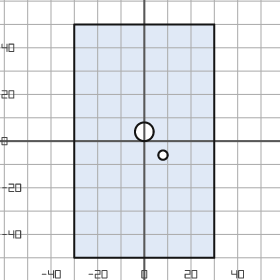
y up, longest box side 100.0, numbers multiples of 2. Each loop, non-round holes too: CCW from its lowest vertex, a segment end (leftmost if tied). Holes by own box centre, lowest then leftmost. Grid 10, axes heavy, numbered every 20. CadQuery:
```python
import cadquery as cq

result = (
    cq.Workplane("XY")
    .moveTo(-30.0, -50.0)
    .lineTo(30.0, -50.0)
    .lineTo(30.0, 50.0)
    .lineTo(-30.0, 50.0)
    .close()
    .moveTo(8.0, -6.0)
    .circle(2.0)
    .moveTo(0.0, 4.0)
    .circle(4.0)
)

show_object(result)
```